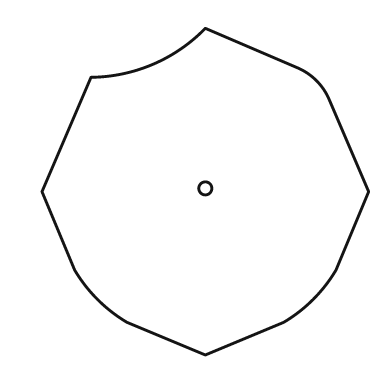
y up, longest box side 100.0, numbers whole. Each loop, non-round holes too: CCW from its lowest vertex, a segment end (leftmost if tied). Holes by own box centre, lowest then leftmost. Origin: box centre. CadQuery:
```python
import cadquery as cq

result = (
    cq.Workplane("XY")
    .moveTo(0.0, -50.0)
    .lineTo(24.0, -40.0)
    .threePointArc((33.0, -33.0), (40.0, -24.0))
    .lineTo(50.0, 0.0)
    .lineTo(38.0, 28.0)
    .threePointArc((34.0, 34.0), (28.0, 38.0))
    .lineTo(0.0, 50.0)
    .threePointArc((-16.0, 39.0), (-35.0, 35.0))
    .lineTo(-50.0, 0.0)
    .lineTo(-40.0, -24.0)
    .threePointArc((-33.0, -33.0), (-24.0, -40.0))
    .close()
    .moveTo(0.0, 1.0)
    .circle(2.0)
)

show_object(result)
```